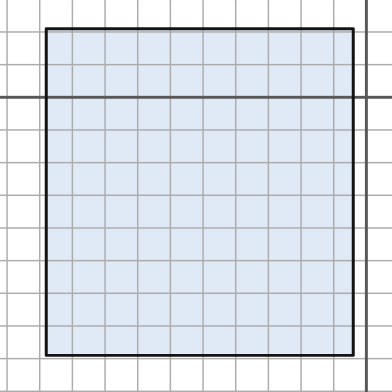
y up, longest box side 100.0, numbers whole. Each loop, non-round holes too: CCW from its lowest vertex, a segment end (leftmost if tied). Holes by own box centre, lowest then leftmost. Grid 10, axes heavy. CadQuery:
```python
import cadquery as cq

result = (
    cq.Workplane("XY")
    .moveTo(-98.0, -79.0)
    .lineTo(-4.0, -79.0)
    .lineTo(-4.0, 21.0)
    .lineTo(-98.0, 21.0)
    .close()
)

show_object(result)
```